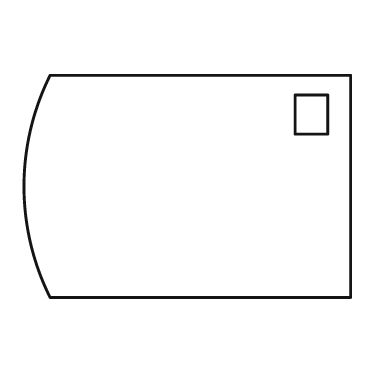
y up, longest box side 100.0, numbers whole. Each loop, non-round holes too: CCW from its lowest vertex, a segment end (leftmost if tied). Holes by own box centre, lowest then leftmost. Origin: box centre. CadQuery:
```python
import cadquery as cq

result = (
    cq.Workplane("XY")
    .moveTo(-42.0, -34.0)
    .lineTo(50.0, -34.0)
    .lineTo(50.0, 34.0)
    .lineTo(-42.0, 34.0)
    .threePointArc((-50.0, 0.0), (-42.0, -34.0))
    .close()
    .moveTo(33.0, 16.0)
    .lineTo(43.0, 16.0)
    .lineTo(43.0, 28.0)
    .lineTo(33.0, 28.0)
    .close()
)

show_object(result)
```